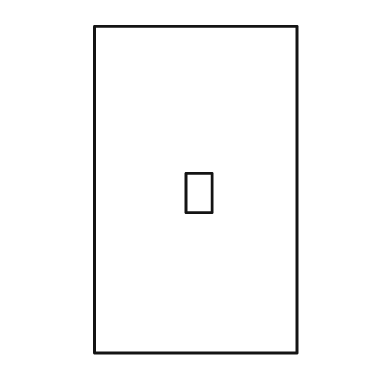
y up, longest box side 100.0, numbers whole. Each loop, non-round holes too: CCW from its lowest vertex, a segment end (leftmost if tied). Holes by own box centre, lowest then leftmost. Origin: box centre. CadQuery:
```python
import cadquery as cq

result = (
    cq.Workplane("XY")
    .moveTo(-31.0, -50.0)
    .lineTo(31.0, -50.0)
    .lineTo(31.0, 50.0)
    .lineTo(-31.0, 50.0)
    .close()
    .moveTo(-3.0, -7.0)
    .lineTo(5.0, -7.0)
    .lineTo(5.0, 5.0)
    .lineTo(-3.0, 5.0)
    .close()
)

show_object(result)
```